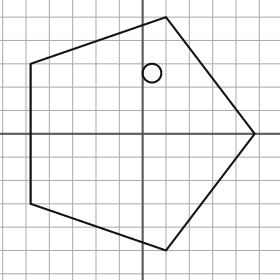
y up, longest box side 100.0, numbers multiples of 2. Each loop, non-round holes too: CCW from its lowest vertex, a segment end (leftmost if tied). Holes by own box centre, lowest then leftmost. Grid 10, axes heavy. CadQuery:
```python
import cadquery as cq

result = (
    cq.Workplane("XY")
    .moveTo(10.0, -50.0)
    .lineTo(48.0, 0.0)
    .lineTo(10.0, 50.0)
    .lineTo(-48.0, 30.0)
    .lineTo(-48.0, -30.0)
    .close()
    .moveTo(4.0, 26.0)
    .circle(4.0)
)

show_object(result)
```